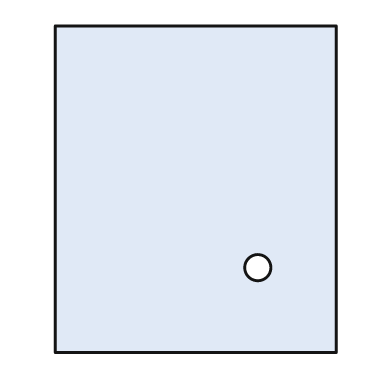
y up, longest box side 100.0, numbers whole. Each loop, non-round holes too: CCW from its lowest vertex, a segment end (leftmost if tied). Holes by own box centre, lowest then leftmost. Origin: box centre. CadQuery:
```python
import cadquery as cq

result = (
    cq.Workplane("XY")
    .moveTo(-43.0, -50.0)
    .lineTo(43.0, -50.0)
    .lineTo(43.0, 50.0)
    .lineTo(-43.0, 50.0)
    .close()
    .moveTo(19.0, -24.0)
    .circle(4.0)
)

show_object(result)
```